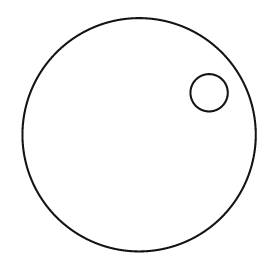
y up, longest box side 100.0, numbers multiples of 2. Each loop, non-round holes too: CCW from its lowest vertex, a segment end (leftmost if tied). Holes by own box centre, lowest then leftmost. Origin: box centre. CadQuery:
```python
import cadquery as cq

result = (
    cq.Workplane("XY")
    .moveTo(0.0, 0.0)
    .circle(50.0)
    .moveTo(30.0, 18.0)
    .circle(8.0)
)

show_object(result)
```